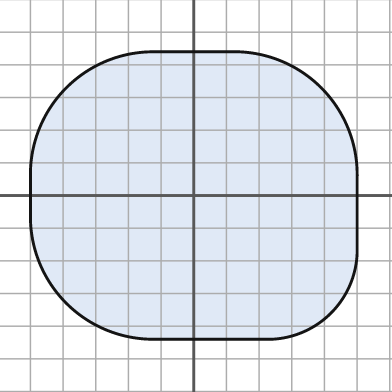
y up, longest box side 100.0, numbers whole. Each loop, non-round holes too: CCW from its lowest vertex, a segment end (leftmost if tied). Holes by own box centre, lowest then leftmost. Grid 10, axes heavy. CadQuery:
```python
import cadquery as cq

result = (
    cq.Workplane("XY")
    .moveTo(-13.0, -44.0)
    .lineTo(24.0, -44.0)
    .threePointArc((42.0, -36.0), (50.0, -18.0))
    .lineTo(50.0, 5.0)
    .threePointArc((39.0, 33.0), (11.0, 44.0))
    .lineTo(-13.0, 44.0)
    .threePointArc((-39.0, 33.0), (-50.0, 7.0))
    .lineTo(-50.0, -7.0)
    .threePointArc((-39.0, -33.0), (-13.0, -44.0))
    .close()
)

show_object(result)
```